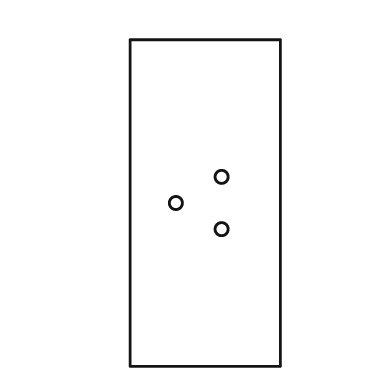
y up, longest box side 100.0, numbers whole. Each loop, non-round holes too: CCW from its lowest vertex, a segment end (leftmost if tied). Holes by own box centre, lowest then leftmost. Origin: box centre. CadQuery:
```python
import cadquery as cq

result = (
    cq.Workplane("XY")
    .moveTo(-23.0, -50.0)
    .lineTo(23.0, -50.0)
    .lineTo(23.0, 50.0)
    .lineTo(-23.0, 50.0)
    .close()
    .moveTo(5.0, -8.0)
    .circle(2.0)
    .moveTo(-9.0, 0.0)
    .circle(2.0)
    .moveTo(5.0, 8.0)
    .circle(2.0)
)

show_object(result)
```